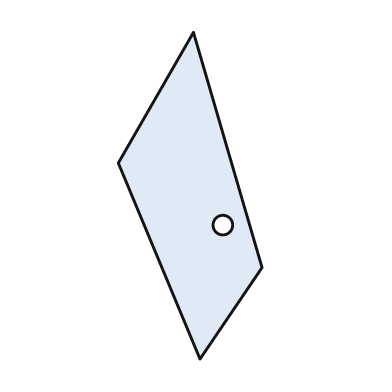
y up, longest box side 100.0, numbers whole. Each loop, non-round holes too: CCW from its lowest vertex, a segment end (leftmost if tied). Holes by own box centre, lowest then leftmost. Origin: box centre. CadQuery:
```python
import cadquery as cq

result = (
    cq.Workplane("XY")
    .moveTo(3.0, -50.0)
    .lineTo(22.0, -22.0)
    .lineTo(1.0, 50.0)
    .lineTo(-22.0, 10.0)
    .close()
    .moveTo(10.0, -9.0)
    .circle(3.0)
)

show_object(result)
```